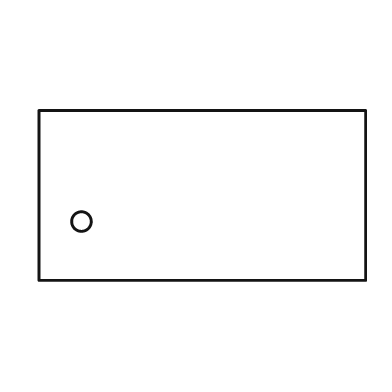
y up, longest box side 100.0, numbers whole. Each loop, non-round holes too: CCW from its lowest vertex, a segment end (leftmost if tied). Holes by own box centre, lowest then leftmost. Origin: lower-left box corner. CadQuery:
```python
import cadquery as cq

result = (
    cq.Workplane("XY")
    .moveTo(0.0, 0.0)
    .lineTo(100.0, 0.0)
    .lineTo(100.0, 52.0)
    .lineTo(0.0, 52.0)
    .close()
    .moveTo(13.0, 18.0)
    .circle(3.0)
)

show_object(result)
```